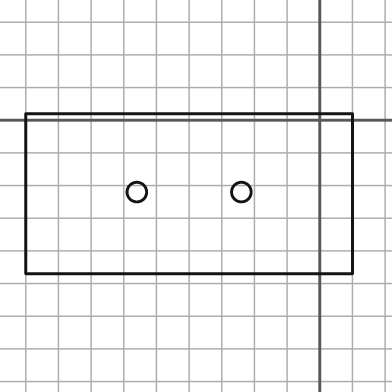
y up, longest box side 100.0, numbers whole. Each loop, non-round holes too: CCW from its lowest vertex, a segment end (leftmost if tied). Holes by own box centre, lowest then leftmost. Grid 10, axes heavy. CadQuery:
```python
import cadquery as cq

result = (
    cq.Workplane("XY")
    .moveTo(-90.0, -47.0)
    .lineTo(10.0, -47.0)
    .lineTo(10.0, 2.0)
    .lineTo(-90.0, 2.0)
    .close()
    .moveTo(-56.0, -22.0)
    .circle(3.0)
    .moveTo(-24.0, -22.0)
    .circle(3.0)
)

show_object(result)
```